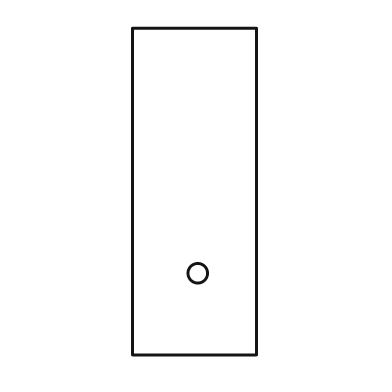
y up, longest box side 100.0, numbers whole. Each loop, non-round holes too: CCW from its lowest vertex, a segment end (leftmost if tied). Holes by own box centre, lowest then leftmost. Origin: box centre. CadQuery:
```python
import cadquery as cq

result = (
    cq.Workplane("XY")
    .moveTo(-19.0, -50.0)
    .lineTo(19.0, -50.0)
    .lineTo(19.0, 50.0)
    .lineTo(-19.0, 50.0)
    .close()
    .moveTo(1.0, -25.0)
    .circle(3.0)
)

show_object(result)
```